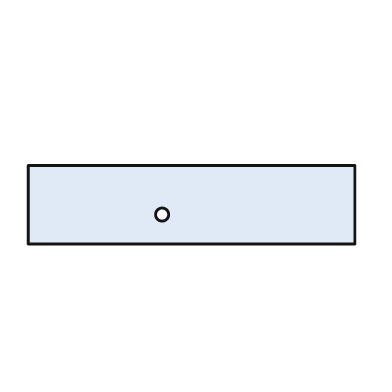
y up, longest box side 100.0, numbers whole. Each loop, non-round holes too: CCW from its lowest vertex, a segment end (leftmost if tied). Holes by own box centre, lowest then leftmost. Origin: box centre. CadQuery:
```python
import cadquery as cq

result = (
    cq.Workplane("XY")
    .moveTo(-50.0, -12.0)
    .lineTo(50.0, -12.0)
    .lineTo(50.0, 12.0)
    .lineTo(-50.0, 12.0)
    .close()
    .moveTo(-9.0, -3.0)
    .circle(2.0)
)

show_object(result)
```